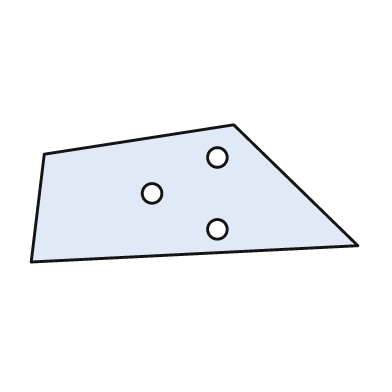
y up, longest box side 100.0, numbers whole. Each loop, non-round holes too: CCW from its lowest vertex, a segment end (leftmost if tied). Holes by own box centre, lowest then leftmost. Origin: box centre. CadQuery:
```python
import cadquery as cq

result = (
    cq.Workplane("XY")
    .moveTo(-50.0, -21.0)
    .lineTo(50.0, -16.0)
    .lineTo(12.0, 21.0)
    .lineTo(-46.0, 12.0)
    .close()
    .moveTo(7.0, -11.0)
    .circle(3.0)
    .moveTo(-13.0, 0.0)
    .circle(3.0)
    .moveTo(7.0, 11.0)
    .circle(3.0)
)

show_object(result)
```